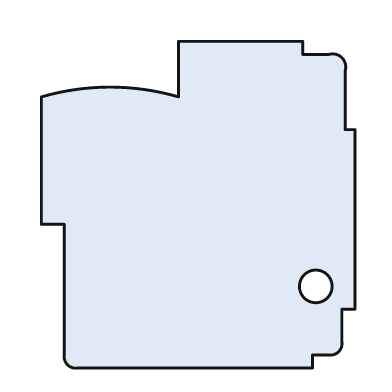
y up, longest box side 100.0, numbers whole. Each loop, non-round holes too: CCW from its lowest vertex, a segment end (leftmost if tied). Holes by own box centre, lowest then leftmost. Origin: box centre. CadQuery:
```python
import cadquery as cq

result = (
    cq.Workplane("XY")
    .moveTo(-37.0, -50.0)
    .lineTo(35.0, -50.0)
    .lineTo(35.0, -46.0)
    .lineTo(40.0, -46.0)
    .threePointArc((43.0, -45.0), (44.0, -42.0))
    .lineTo(44.0, -32.0)
    .lineTo(48.0, -32.0)
    .lineTo(48.0, 23.0)
    .lineTo(45.0, 23.0)
    .lineTo(45.0, 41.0)
    .threePointArc((44.0, 45.0), (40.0, 46.0))
    .lineTo(32.0, 46.0)
    .lineTo(32.0, 50.0)
    .lineTo(-6.0, 50.0)
    .lineTo(-6.0, 33.0)
    .threePointArc((-27.0, 36.0), (-48.0, 33.0))
    .lineTo(-48.0, -6.0)
    .lineTo(-41.0, -6.0)
    .lineTo(-41.0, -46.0)
    .threePointArc((-40.0, -49.0), (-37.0, -50.0))
    .close()
    .moveTo(36.0, -25.0)
    .circle(5.0)
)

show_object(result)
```